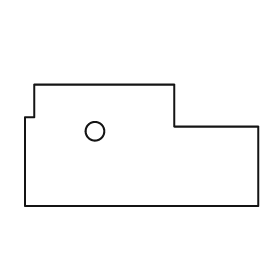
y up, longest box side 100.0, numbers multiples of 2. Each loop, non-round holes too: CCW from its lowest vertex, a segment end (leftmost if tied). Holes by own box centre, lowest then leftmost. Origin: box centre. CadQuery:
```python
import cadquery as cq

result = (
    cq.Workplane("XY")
    .moveTo(-50.0, -26.0)
    .lineTo(50.0, -26.0)
    .lineTo(50.0, 8.0)
    .lineTo(14.0, 8.0)
    .lineTo(14.0, 26.0)
    .lineTo(-46.0, 26.0)
    .lineTo(-46.0, 12.0)
    .lineTo(-50.0, 12.0)
    .close()
    .moveTo(-20.0, 6.0)
    .circle(4.0)
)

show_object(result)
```